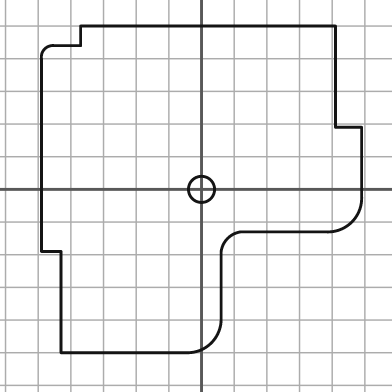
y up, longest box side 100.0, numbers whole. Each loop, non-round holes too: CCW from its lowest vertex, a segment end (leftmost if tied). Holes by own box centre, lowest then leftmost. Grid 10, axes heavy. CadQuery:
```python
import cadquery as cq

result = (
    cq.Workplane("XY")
    .moveTo(-43.0, -50.0)
    .lineTo(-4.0, -50.0)
    .threePointArc((3.0, -47.0), (6.0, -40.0))
    .lineTo(6.0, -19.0)
    .threePointArc((8.0, -15.0), (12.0, -13.0))
    .lineTo(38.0, -13.0)
    .threePointArc((46.0, -10.0), (49.0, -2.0))
    .lineTo(49.0, 19.0)
    .lineTo(41.0, 19.0)
    .lineTo(41.0, 50.0)
    .lineTo(-37.0, 50.0)
    .lineTo(-37.0, 44.0)
    .lineTo(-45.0, 44.0)
    .threePointArc((-48.0, 43.0), (-49.0, 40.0))
    .lineTo(-49.0, -19.0)
    .lineTo(-43.0, -19.0)
    .close()
    .moveTo(0.0, 0.0)
    .circle(4.0)
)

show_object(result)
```